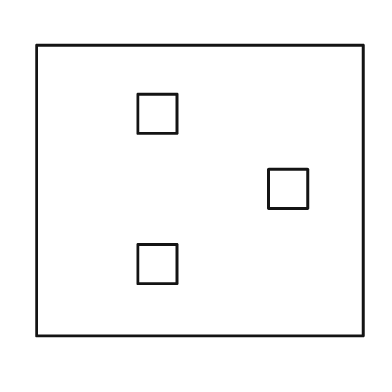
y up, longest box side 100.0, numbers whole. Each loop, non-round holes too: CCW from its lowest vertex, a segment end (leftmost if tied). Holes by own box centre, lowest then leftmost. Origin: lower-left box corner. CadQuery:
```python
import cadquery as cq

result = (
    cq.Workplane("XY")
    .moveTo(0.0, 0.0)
    .lineTo(100.0, 0.0)
    .lineTo(100.0, 89.0)
    .lineTo(0.0, 89.0)
    .close()
    .moveTo(31.0, 16.0)
    .lineTo(43.0, 16.0)
    .lineTo(43.0, 28.0)
    .lineTo(31.0, 28.0)
    .close()
    .moveTo(71.0, 39.0)
    .lineTo(83.0, 39.0)
    .lineTo(83.0, 51.0)
    .lineTo(71.0, 51.0)
    .close()
    .moveTo(31.0, 62.0)
    .lineTo(43.0, 62.0)
    .lineTo(43.0, 74.0)
    .lineTo(31.0, 74.0)
    .close()
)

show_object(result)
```